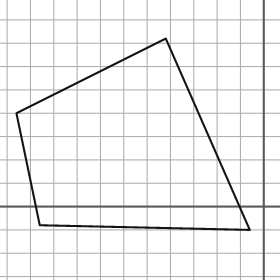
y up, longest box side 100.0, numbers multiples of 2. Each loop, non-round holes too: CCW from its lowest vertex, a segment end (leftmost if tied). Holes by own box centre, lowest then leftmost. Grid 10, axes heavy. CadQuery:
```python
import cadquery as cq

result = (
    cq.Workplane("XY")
    .moveTo(-6.0, -10.0)
    .lineTo(-42.0, 72.0)
    .lineTo(-106.0, 40.0)
    .lineTo(-96.0, -8.0)
    .close()
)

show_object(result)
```